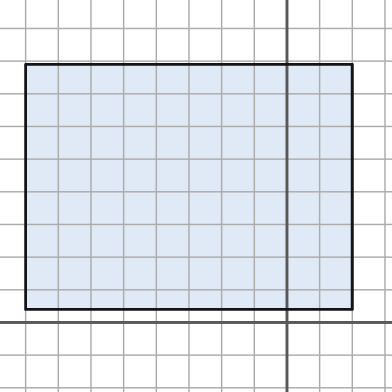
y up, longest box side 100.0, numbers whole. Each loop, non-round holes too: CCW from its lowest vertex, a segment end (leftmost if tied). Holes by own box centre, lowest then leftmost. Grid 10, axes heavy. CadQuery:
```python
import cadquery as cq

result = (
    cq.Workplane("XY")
    .moveTo(-80.0, 4.0)
    .lineTo(20.0, 4.0)
    .lineTo(20.0, 79.0)
    .lineTo(-80.0, 79.0)
    .close()
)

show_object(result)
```